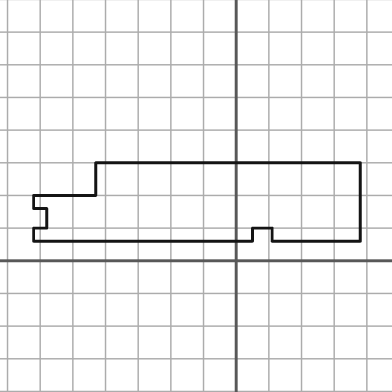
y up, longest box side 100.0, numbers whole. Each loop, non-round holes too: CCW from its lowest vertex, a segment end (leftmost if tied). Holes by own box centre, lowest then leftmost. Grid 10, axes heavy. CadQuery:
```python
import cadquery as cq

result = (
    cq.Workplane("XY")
    .moveTo(-62.0, 6.0)
    .lineTo(5.0, 6.0)
    .lineTo(5.0, 10.0)
    .lineTo(11.0, 10.0)
    .lineTo(11.0, 6.0)
    .lineTo(38.0, 6.0)
    .lineTo(38.0, 30.0)
    .lineTo(-43.0, 30.0)
    .lineTo(-43.0, 20.0)
    .lineTo(-62.0, 20.0)
    .lineTo(-62.0, 16.0)
    .lineTo(-58.0, 16.0)
    .lineTo(-58.0, 10.0)
    .lineTo(-62.0, 10.0)
    .close()
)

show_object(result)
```